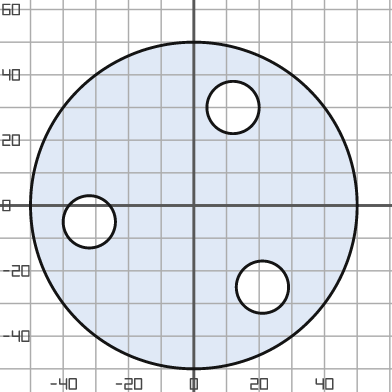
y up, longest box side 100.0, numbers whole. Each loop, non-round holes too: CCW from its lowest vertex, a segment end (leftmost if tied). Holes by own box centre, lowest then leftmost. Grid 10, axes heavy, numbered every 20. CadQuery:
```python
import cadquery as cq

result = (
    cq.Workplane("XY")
    .moveTo(0.0, 0.0)
    .circle(50.0)
    .moveTo(21.0, -25.0)
    .circle(8.0)
    .moveTo(-32.0, -5.0)
    .circle(8.0)
    .moveTo(12.0, 30.0)
    .circle(8.0)
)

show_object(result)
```